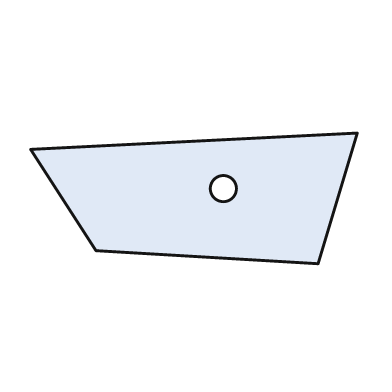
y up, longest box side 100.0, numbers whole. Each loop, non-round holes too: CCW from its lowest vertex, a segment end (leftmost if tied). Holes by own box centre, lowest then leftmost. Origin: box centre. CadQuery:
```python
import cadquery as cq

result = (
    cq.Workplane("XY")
    .moveTo(38.0, -20.0)
    .lineTo(50.0, 20.0)
    .lineTo(-50.0, 15.0)
    .lineTo(-30.0, -16.0)
    .close()
    .moveTo(9.0, 3.0)
    .circle(4.0)
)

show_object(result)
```